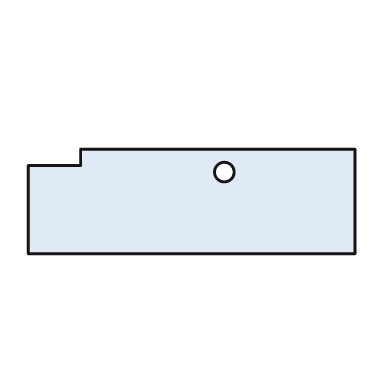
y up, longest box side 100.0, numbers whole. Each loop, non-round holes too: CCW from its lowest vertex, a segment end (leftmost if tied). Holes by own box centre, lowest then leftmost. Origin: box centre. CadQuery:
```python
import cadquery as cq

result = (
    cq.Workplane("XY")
    .moveTo(-50.0, -16.0)
    .lineTo(50.0, -16.0)
    .lineTo(50.0, 16.0)
    .lineTo(-34.0, 16.0)
    .lineTo(-34.0, 11.0)
    .lineTo(-50.0, 11.0)
    .close()
    .moveTo(10.0, 9.0)
    .circle(3.0)
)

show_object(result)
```